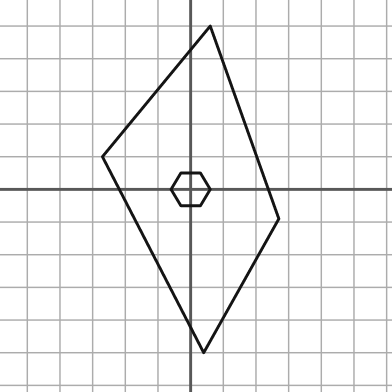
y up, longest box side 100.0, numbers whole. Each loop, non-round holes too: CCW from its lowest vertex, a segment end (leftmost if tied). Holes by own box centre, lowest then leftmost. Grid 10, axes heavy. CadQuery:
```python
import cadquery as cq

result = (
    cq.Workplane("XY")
    .moveTo(4.0, -50.0)
    .lineTo(27.0, -9.0)
    .lineTo(6.0, 50.0)
    .lineTo(-27.0, 10.0)
    .close()
    .moveTo(-3.0, -5.0)
    .lineTo(3.0, -5.0)
    .lineTo(6.0, 0.0)
    .lineTo(3.0, 5.0)
    .lineTo(-3.0, 5.0)
    .lineTo(-6.0, 0.0)
    .close()
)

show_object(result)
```